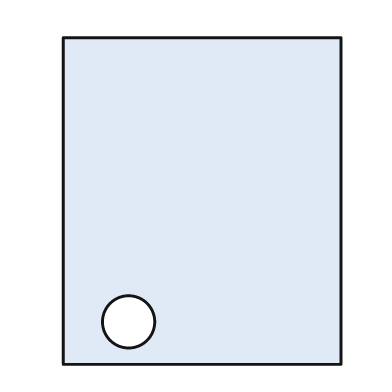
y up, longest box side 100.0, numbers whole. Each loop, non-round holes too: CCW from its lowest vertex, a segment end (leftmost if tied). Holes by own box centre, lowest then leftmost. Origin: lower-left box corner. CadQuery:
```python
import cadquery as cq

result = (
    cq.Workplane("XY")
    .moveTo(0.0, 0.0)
    .lineTo(85.0, 0.0)
    .lineTo(85.0, 100.0)
    .lineTo(0.0, 100.0)
    .close()
    .moveTo(20.0, 13.0)
    .circle(8.0)
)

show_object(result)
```